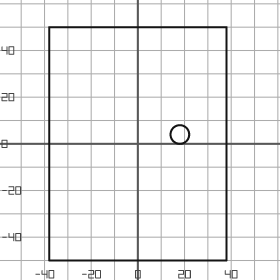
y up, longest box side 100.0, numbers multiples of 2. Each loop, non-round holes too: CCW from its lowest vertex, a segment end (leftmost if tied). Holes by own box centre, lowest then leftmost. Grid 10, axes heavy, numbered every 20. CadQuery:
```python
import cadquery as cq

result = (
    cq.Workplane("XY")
    .moveTo(-38.0, -50.0)
    .lineTo(38.0, -50.0)
    .lineTo(38.0, 50.0)
    .lineTo(-38.0, 50.0)
    .close()
    .moveTo(18.0, 4.0)
    .circle(4.0)
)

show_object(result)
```